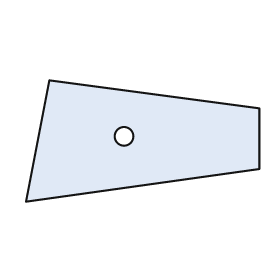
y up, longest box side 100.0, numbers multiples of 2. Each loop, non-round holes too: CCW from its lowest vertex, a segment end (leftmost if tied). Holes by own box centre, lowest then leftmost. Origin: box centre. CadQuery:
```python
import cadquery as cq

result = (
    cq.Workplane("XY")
    .moveTo(-50.0, -26.0)
    .lineTo(50.0, -12.0)
    .lineTo(50.0, 14.0)
    .lineTo(-40.0, 26.0)
    .close()
    .moveTo(-8.0, 2.0)
    .circle(4.0)
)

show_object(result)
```